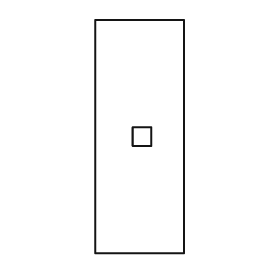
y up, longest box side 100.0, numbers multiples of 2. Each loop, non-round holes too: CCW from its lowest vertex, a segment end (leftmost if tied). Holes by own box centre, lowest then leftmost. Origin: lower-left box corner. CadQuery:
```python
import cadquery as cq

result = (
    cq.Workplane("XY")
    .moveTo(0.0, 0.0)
    .lineTo(38.0, 0.0)
    .lineTo(38.0, 100.0)
    .lineTo(0.0, 100.0)
    .close()
    .moveTo(16.0, 46.0)
    .lineTo(24.0, 46.0)
    .lineTo(24.0, 54.0)
    .lineTo(16.0, 54.0)
    .close()
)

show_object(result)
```